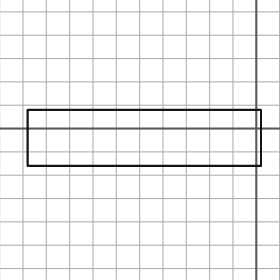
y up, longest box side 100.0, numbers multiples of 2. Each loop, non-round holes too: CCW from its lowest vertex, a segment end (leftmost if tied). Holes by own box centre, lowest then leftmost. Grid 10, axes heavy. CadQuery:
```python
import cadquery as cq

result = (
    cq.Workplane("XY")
    .moveTo(-98.0, -16.0)
    .lineTo(2.0, -16.0)
    .lineTo(2.0, 8.0)
    .lineTo(-98.0, 8.0)
    .close()
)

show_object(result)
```